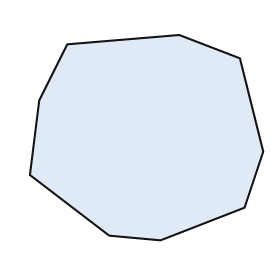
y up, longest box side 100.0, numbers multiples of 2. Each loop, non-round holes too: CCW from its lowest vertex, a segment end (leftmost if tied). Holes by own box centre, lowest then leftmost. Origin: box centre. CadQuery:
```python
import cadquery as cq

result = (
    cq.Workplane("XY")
    .moveTo(6.0, -44.0)
    .lineTo(42.0, -30.0)
    .lineTo(50.0, -6.0)
    .lineTo(40.0, 34.0)
    .lineTo(14.0, 44.0)
    .lineTo(-34.0, 40.0)
    .lineTo(-46.0, 16.0)
    .lineTo(-50.0, -16.0)
    .lineTo(-16.0, -42.0)
    .close()
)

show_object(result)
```